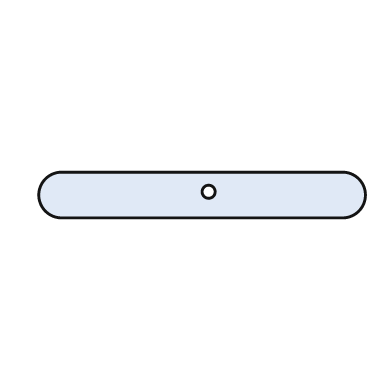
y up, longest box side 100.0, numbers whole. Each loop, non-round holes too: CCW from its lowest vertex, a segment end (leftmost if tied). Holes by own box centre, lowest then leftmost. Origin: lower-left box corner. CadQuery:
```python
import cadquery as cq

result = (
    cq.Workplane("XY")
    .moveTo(7.0, 0.0)
    .lineTo(93.0, 0.0)
    .threePointArc((100.0, 7.0), (93.0, 14.0))
    .lineTo(7.0, 14.0)
    .threePointArc((0.0, 7.0), (7.0, 0.0))
    .close()
    .moveTo(52.0, 8.0)
    .circle(2.0)
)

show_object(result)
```